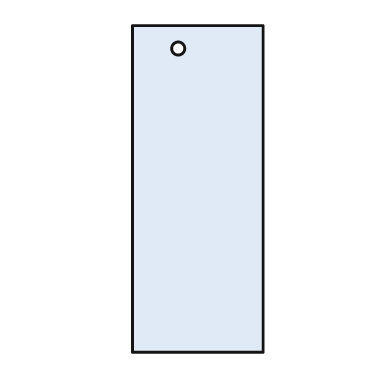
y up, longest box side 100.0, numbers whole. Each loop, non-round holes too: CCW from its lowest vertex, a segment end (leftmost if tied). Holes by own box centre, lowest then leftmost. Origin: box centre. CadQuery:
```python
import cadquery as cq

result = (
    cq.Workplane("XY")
    .moveTo(-20.0, -50.0)
    .lineTo(20.0, -50.0)
    .lineTo(20.0, 50.0)
    .lineTo(-20.0, 50.0)
    .close()
    .moveTo(-6.0, 43.0)
    .circle(2.0)
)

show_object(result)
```